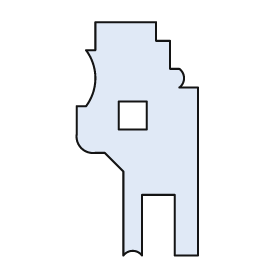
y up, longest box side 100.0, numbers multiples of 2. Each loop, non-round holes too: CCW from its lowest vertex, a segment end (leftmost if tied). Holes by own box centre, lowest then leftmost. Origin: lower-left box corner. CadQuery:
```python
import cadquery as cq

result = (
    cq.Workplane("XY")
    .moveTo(20.0, 0.0)
    .threePointArc((24.0, 2.0), (28.0, 0.0))
    .lineTo(28.0, 26.0)
    .lineTo(42.0, 26.0)
    .lineTo(42.0, 0.0)
    .lineTo(52.0, 0.0)
    .lineTo(52.0, 72.0)
    .lineTo(44.0, 72.0)
    .threePointArc((46.0, 76.0), (44.0, 80.0))
    .lineTo(40.0, 80.0)
    .lineTo(40.0, 92.0)
    .lineTo(34.0, 92.0)
    .lineTo(34.0, 100.0)
    .lineTo(8.0, 100.0)
    .lineTo(8.0, 88.0)
    .lineTo(4.0, 88.0)
    .threePointArc((8.0, 76.0), (4.0, 64.0))
    .lineTo(0.0, 64.0)
    .lineTo(0.0, 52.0)
    .threePointArc((2.0, 46.0), (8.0, 44.0))
    .lineTo(12.0, 44.0)
    .lineTo(20.0, 36.0)
    .close()
    .moveTo(18.0, 54.0)
    .lineTo(30.0, 54.0)
    .lineTo(30.0, 66.0)
    .lineTo(18.0, 66.0)
    .close()
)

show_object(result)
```